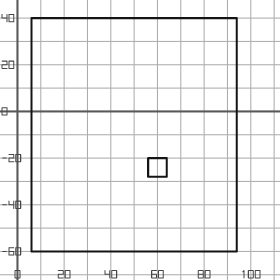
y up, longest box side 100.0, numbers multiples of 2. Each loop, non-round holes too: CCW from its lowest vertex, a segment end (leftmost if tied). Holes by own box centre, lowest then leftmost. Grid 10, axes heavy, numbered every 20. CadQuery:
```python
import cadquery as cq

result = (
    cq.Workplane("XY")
    .moveTo(6.0, -60.0)
    .lineTo(94.0, -60.0)
    .lineTo(94.0, 40.0)
    .lineTo(6.0, 40.0)
    .close()
    .moveTo(56.0, -28.0)
    .lineTo(64.0, -28.0)
    .lineTo(64.0, -20.0)
    .lineTo(56.0, -20.0)
    .close()
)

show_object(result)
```